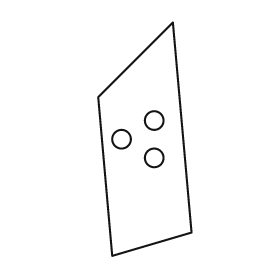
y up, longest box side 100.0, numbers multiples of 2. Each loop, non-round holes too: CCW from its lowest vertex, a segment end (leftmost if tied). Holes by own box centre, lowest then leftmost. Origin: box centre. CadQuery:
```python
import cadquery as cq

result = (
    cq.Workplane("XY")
    .moveTo(-14.0, -50.0)
    .lineTo(20.0, -40.0)
    .lineTo(12.0, 50.0)
    .lineTo(-20.0, 18.0)
    .close()
    .moveTo(4.0, -8.0)
    .circle(4.0)
    .moveTo(-10.0, 0.0)
    .circle(4.0)
    .moveTo(4.0, 8.0)
    .circle(4.0)
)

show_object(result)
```